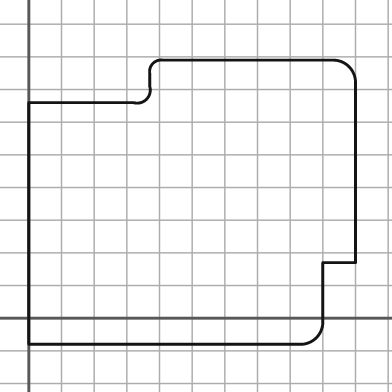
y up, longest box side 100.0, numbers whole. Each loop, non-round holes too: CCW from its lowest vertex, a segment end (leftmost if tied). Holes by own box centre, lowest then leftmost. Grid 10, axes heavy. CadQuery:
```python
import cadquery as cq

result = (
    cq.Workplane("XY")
    .moveTo(0.0, -8.0)
    .lineTo(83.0, -8.0)
    .threePointArc((88.0, -6.0), (90.0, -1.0))
    .lineTo(90.0, 17.0)
    .lineTo(100.0, 17.0)
    .lineTo(100.0, 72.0)
    .threePointArc((98.0, 77.0), (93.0, 79.0))
    .lineTo(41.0, 79.0)
    .threePointArc((38.0, 78.0), (37.0, 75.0))
    .lineTo(37.0, 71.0)
    .threePointArc((36.0, 67.0), (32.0, 66.0))
    .lineTo(0.0, 66.0)
    .close()
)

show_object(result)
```